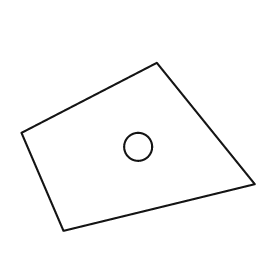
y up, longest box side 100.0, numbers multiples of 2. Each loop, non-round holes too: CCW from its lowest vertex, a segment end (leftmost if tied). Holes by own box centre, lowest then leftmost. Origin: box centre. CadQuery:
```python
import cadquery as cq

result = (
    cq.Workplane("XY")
    .moveTo(-32.0, -36.0)
    .lineTo(50.0, -16.0)
    .lineTo(8.0, 36.0)
    .lineTo(-50.0, 6.0)
    .close()
    .moveTo(0.0, 0.0)
    .circle(6.0)
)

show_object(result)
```